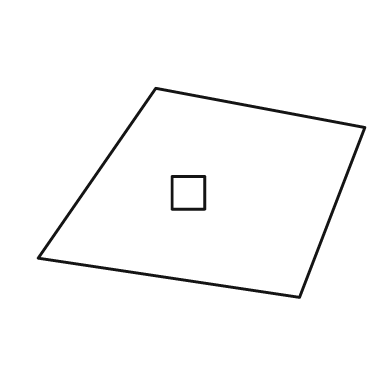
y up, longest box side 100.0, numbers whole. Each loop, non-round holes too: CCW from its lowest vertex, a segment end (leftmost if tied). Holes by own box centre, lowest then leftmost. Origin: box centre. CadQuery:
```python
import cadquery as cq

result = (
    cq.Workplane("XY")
    .moveTo(30.0, -32.0)
    .lineTo(50.0, 20.0)
    .lineTo(-14.0, 32.0)
    .lineTo(-50.0, -20.0)
    .close()
    .moveTo(-9.0, -5.0)
    .lineTo(1.0, -5.0)
    .lineTo(1.0, 5.0)
    .lineTo(-9.0, 5.0)
    .close()
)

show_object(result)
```